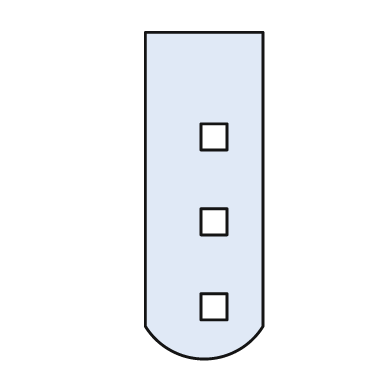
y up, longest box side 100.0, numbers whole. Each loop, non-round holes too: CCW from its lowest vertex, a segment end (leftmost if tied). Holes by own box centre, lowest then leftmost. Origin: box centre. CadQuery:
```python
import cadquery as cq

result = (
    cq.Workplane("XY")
    .moveTo(-18.0, -40.0)
    .threePointArc((0.0, -50.0), (18.0, -40.0))
    .lineTo(18.0, 50.0)
    .lineTo(-18.0, 50.0)
    .close()
    .moveTo(-1.0, -38.0)
    .lineTo(7.0, -38.0)
    .lineTo(7.0, -30.0)
    .lineTo(-1.0, -30.0)
    .close()
    .moveTo(-1.0, -12.0)
    .lineTo(7.0, -12.0)
    .lineTo(7.0, -4.0)
    .lineTo(-1.0, -4.0)
    .close()
    .moveTo(-1.0, 14.0)
    .lineTo(7.0, 14.0)
    .lineTo(7.0, 22.0)
    .lineTo(-1.0, 22.0)
    .close()
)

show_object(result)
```